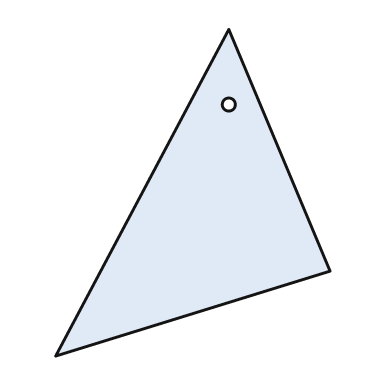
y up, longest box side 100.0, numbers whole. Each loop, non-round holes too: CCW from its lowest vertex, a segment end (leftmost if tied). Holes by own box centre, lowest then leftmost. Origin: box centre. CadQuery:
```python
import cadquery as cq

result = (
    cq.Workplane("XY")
    .moveTo(-42.0, -50.0)
    .lineTo(42.0, -24.0)
    .lineTo(11.0, 50.0)
    .close()
    .moveTo(11.0, 27.0)
    .circle(2.0)
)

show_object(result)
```